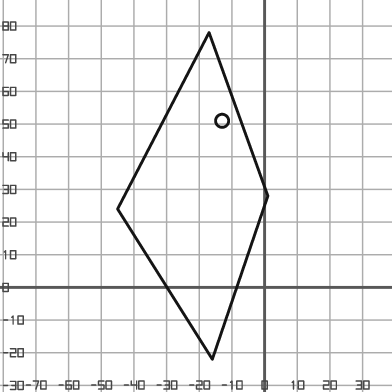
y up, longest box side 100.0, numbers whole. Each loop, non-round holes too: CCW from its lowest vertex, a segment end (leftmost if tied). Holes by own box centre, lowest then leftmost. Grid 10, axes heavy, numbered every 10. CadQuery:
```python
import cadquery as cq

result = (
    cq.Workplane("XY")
    .moveTo(-16.0, -22.0)
    .lineTo(1.0, 28.0)
    .lineTo(-17.0, 78.0)
    .lineTo(-45.0, 24.0)
    .close()
    .moveTo(-13.0, 51.0)
    .circle(2.0)
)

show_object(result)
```